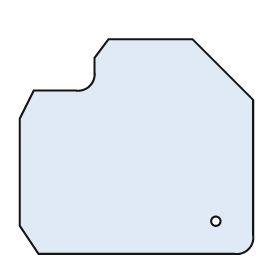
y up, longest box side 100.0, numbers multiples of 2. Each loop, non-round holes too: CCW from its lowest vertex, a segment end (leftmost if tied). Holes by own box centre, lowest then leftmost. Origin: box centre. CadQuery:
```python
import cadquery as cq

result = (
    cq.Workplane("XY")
    .moveTo(-42.0, -46.0)
    .lineTo(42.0, -46.0)
    .threePointArc((48.0, -44.0), (50.0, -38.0))
    .lineTo(50.0, 20.0)
    .lineTo(24.0, 46.0)
    .lineTo(-12.0, 46.0)
    .lineTo(-18.0, 38.0)
    .lineTo(-18.0, 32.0)
    .threePointArc((-20.0, 26.0), (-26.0, 24.0))
    .lineTo(-44.0, 24.0)
    .lineTo(-50.0, 12.0)
    .lineTo(-50.0, -34.0)
    .close()
    .moveTo(34.0, -32.0)
    .circle(2.0)
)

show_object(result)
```